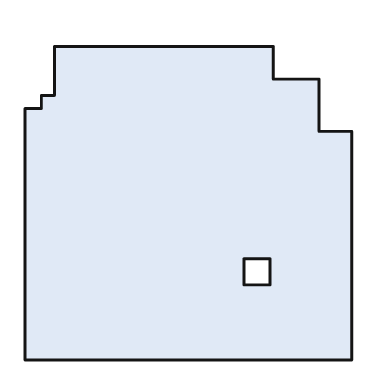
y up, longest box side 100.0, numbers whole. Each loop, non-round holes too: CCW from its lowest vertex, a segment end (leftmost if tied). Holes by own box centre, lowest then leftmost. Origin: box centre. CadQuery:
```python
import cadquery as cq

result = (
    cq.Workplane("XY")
    .moveTo(-50.0, -48.0)
    .lineTo(50.0, -48.0)
    .lineTo(50.0, 22.0)
    .lineTo(40.0, 22.0)
    .lineTo(40.0, 38.0)
    .lineTo(26.0, 38.0)
    .lineTo(26.0, 48.0)
    .lineTo(-41.0, 48.0)
    .lineTo(-41.0, 33.0)
    .lineTo(-45.0, 33.0)
    .lineTo(-45.0, 29.0)
    .lineTo(-50.0, 29.0)
    .close()
    .moveTo(17.0, -25.0)
    .lineTo(25.0, -25.0)
    .lineTo(25.0, -17.0)
    .lineTo(17.0, -17.0)
    .close()
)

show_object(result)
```